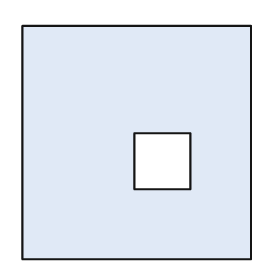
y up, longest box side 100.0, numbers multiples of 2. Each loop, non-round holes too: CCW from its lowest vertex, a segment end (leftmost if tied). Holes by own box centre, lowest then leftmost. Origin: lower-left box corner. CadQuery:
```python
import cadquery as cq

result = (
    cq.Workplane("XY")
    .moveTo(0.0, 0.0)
    .lineTo(98.0, 0.0)
    .lineTo(98.0, 100.0)
    .lineTo(0.0, 100.0)
    .close()
    .moveTo(48.0, 30.0)
    .lineTo(72.0, 30.0)
    .lineTo(72.0, 54.0)
    .lineTo(48.0, 54.0)
    .close()
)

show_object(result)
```